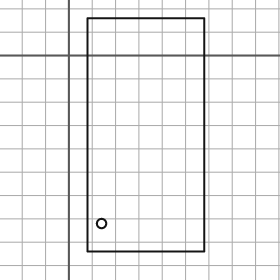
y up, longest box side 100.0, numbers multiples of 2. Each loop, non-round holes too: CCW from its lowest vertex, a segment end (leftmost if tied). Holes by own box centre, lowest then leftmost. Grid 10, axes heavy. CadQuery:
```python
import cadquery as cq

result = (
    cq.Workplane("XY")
    .moveTo(8.0, -84.0)
    .lineTo(58.0, -84.0)
    .lineTo(58.0, 16.0)
    .lineTo(8.0, 16.0)
    .close()
    .moveTo(14.0, -72.0)
    .circle(2.0)
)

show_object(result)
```